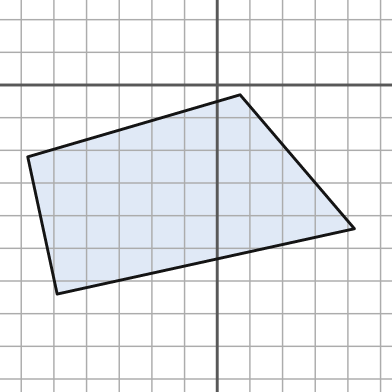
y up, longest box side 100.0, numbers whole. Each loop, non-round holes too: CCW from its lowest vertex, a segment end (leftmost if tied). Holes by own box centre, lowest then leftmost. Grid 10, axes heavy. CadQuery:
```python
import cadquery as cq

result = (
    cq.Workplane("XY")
    .moveTo(-49.0, -64.0)
    .lineTo(42.0, -44.0)
    .lineTo(7.0, -3.0)
    .lineTo(-58.0, -22.0)
    .close()
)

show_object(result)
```